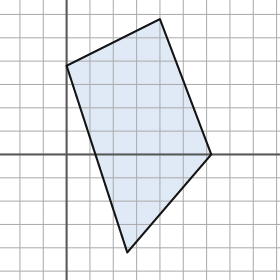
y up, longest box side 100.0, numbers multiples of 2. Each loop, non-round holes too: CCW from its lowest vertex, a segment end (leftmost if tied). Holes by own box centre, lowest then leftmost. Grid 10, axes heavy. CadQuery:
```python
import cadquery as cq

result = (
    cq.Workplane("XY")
    .moveTo(26.0, -42.0)
    .lineTo(62.0, 0.0)
    .lineTo(40.0, 58.0)
    .lineTo(0.0, 38.0)
    .close()
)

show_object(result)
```